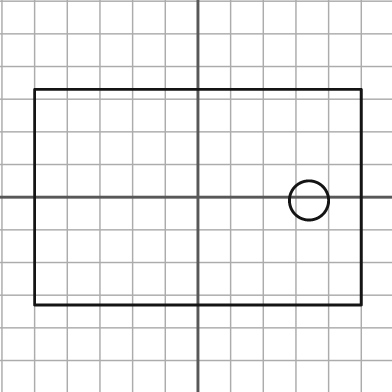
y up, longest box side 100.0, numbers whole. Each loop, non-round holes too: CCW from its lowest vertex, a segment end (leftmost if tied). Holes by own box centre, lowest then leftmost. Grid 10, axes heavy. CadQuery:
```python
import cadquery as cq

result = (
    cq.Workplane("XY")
    .moveTo(-50.0, -33.0)
    .lineTo(50.0, -33.0)
    .lineTo(50.0, 33.0)
    .lineTo(-50.0, 33.0)
    .close()
    .moveTo(34.0, -1.0)
    .circle(6.0)
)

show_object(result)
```